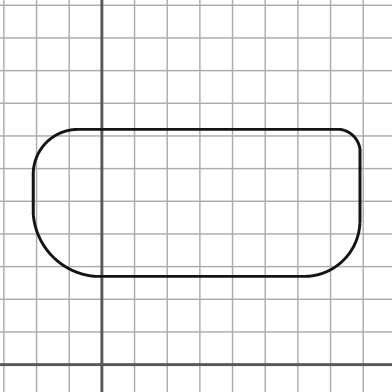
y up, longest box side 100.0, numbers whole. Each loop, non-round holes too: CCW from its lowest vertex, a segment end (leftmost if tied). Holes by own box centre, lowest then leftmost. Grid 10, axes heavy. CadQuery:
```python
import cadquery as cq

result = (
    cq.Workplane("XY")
    .moveTo(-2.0, 27.0)
    .lineTo(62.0, 27.0)
    .threePointArc((74.0, 32.0), (79.0, 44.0))
    .lineTo(79.0, 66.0)
    .threePointArc((77.0, 70.0), (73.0, 72.0))
    .lineTo(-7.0, 72.0)
    .threePointArc((-17.0, 68.0), (-21.0, 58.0))
    .lineTo(-21.0, 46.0)
    .threePointArc((-15.0, 33.0), (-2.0, 27.0))
    .close()
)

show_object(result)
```